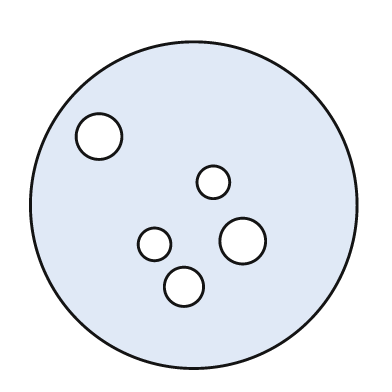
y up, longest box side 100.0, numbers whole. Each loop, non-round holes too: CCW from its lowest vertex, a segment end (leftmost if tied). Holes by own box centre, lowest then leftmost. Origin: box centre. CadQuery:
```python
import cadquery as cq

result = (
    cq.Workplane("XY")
    .moveTo(0.0, 0.0)
    .circle(50.0)
    .moveTo(-3.0, -25.0)
    .circle(6.0)
    .moveTo(-12.0, -12.0)
    .circle(5.0)
    .moveTo(15.0, -11.0)
    .circle(7.0)
    .moveTo(6.0, 7.0)
    .circle(5.0)
    .moveTo(-29.0, 21.0)
    .circle(7.0)
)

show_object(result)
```